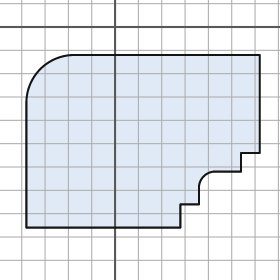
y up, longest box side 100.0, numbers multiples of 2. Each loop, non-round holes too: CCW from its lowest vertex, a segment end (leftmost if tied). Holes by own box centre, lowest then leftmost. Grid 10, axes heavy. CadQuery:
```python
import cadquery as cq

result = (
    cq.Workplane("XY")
    .moveTo(-38.0, -86.0)
    .lineTo(28.0, -86.0)
    .lineTo(28.0, -76.0)
    .lineTo(36.0, -76.0)
    .lineTo(36.0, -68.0)
    .threePointArc((38.0, -64.0), (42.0, -62.0))
    .lineTo(54.0, -62.0)
    .lineTo(54.0, -54.0)
    .lineTo(62.0, -54.0)
    .lineTo(62.0, -12.0)
    .lineTo(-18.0, -12.0)
    .threePointArc((-32.0, -18.0), (-38.0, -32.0))
    .close()
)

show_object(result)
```